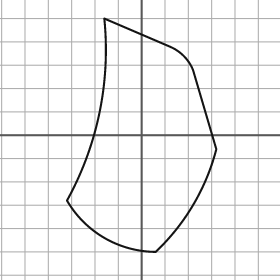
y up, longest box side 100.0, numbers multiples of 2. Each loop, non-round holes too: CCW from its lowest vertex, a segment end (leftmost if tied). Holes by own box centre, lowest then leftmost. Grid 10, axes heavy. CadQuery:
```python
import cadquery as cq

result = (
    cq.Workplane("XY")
    .moveTo(6.0, -50.0)
    .threePointArc((22.0, -30.0), (32.0, -6.0))
    .lineTo(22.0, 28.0)
    .threePointArc((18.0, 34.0), (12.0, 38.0))
    .lineTo(-16.0, 50.0)
    .threePointArc((-18.0, 10.0), (-32.0, -28.0))
    .threePointArc((-16.0, -44.0), (6.0, -50.0))
    .close()
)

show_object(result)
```